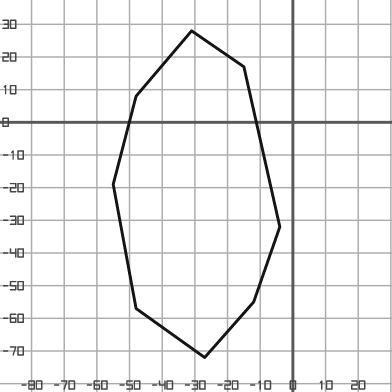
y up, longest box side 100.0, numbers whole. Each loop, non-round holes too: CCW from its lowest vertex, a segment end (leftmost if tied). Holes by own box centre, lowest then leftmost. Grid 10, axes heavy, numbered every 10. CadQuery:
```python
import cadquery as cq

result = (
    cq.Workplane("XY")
    .moveTo(-27.0, -72.0)
    .lineTo(-12.0, -55.0)
    .lineTo(-4.0, -32.0)
    .lineTo(-15.0, 17.0)
    .lineTo(-31.0, 28.0)
    .lineTo(-48.0, 8.0)
    .lineTo(-55.0, -19.0)
    .lineTo(-48.0, -57.0)
    .close()
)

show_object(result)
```